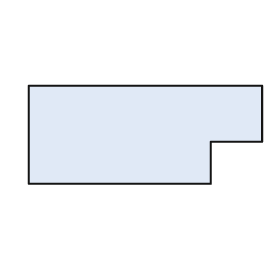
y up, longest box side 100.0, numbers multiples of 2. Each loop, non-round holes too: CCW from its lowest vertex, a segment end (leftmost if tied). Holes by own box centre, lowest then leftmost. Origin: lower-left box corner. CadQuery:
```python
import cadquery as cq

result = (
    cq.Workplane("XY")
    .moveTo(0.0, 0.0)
    .lineTo(78.0, 0.0)
    .lineTo(78.0, 18.0)
    .lineTo(100.0, 18.0)
    .lineTo(100.0, 42.0)
    .lineTo(0.0, 42.0)
    .close()
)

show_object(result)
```